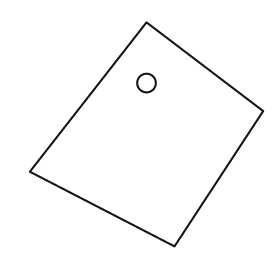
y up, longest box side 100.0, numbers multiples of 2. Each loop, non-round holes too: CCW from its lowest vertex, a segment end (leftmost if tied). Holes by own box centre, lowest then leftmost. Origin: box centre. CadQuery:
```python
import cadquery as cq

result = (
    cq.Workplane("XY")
    .moveTo(12.0, -48.0)
    .lineTo(50.0, 10.0)
    .lineTo(0.0, 48.0)
    .lineTo(-50.0, -16.0)
    .close()
    .moveTo(0.0, 22.0)
    .circle(4.0)
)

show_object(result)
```